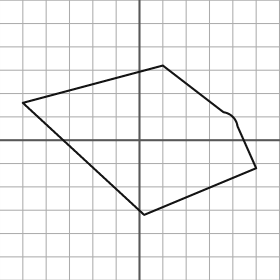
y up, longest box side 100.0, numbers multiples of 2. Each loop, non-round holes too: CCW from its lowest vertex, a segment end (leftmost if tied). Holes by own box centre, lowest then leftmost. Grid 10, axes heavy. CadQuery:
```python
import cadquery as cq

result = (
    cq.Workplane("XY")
    .moveTo(2.0, -32.0)
    .lineTo(50.0, -12.0)
    .lineTo(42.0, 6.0)
    .threePointArc((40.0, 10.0), (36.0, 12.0))
    .lineTo(10.0, 32.0)
    .lineTo(-50.0, 16.0)
    .close()
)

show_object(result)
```